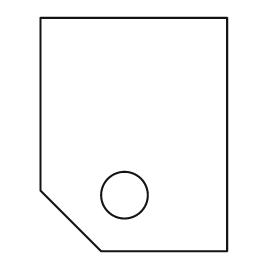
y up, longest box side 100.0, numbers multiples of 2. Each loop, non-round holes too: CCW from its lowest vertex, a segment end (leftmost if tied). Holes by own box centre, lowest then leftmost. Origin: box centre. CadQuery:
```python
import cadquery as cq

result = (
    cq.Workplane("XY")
    .moveTo(-14.0, -50.0)
    .lineTo(40.0, -50.0)
    .lineTo(40.0, 50.0)
    .lineTo(-40.0, 50.0)
    .lineTo(-40.0, -24.0)
    .close()
    .moveTo(-4.0, -26.0)
    .circle(10.0)
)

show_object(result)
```